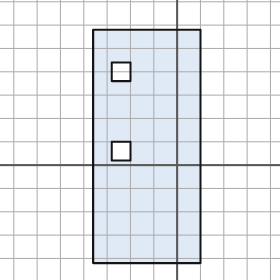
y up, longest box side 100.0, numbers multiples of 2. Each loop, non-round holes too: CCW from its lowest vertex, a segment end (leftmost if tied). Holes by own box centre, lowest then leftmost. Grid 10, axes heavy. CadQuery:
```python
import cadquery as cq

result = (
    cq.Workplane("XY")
    .moveTo(-36.0, -42.0)
    .lineTo(10.0, -42.0)
    .lineTo(10.0, 58.0)
    .lineTo(-36.0, 58.0)
    .close()
    .moveTo(-28.0, 2.0)
    .lineTo(-20.0, 2.0)
    .lineTo(-20.0, 10.0)
    .lineTo(-28.0, 10.0)
    .close()
    .moveTo(-28.0, 36.0)
    .lineTo(-20.0, 36.0)
    .lineTo(-20.0, 44.0)
    .lineTo(-28.0, 44.0)
    .close()
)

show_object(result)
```